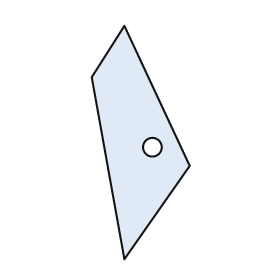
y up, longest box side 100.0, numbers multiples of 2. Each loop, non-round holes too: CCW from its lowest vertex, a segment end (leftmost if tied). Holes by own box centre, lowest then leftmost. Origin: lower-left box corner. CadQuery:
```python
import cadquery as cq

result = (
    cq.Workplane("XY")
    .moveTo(14.0, 0.0)
    .lineTo(42.0, 40.0)
    .lineTo(14.0, 100.0)
    .lineTo(0.0, 78.0)
    .close()
    .moveTo(26.0, 48.0)
    .circle(4.0)
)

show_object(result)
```